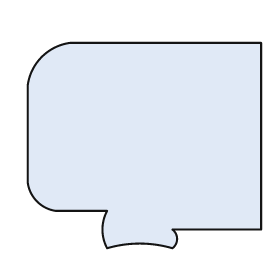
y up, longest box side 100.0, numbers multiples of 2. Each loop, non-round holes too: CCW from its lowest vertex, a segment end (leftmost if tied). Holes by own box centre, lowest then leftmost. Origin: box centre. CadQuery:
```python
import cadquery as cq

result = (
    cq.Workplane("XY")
    .moveTo(-16.0, -44.0)
    .threePointArc((-2.0, -42.0), (12.0, -44.0))
    .threePointArc((14.0, -40.0), (12.0, -36.0))
    .lineTo(50.0, -36.0)
    .lineTo(50.0, 44.0)
    .lineTo(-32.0, 44.0)
    .threePointArc((-44.0, 38.0), (-50.0, 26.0))
    .lineTo(-50.0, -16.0)
    .threePointArc((-46.0, -24.0), (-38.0, -28.0))
    .lineTo(-16.0, -28.0)
    .threePointArc((-18.0, -36.0), (-16.0, -44.0))
    .close()
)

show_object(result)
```